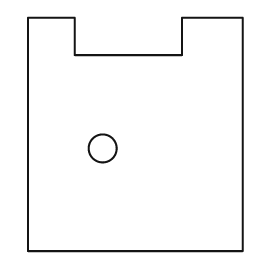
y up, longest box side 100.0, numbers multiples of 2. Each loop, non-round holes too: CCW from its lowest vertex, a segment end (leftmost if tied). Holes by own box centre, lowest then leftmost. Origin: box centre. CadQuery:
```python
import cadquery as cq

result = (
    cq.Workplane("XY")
    .moveTo(-46.0, -50.0)
    .lineTo(46.0, -50.0)
    .lineTo(46.0, 50.0)
    .lineTo(20.0, 50.0)
    .lineTo(20.0, 34.0)
    .lineTo(-26.0, 34.0)
    .lineTo(-26.0, 50.0)
    .lineTo(-46.0, 50.0)
    .close()
    .moveTo(-14.0, -6.0)
    .circle(6.0)
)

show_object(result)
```